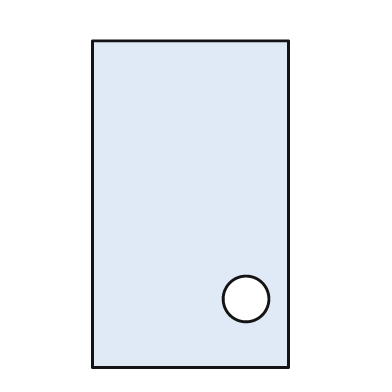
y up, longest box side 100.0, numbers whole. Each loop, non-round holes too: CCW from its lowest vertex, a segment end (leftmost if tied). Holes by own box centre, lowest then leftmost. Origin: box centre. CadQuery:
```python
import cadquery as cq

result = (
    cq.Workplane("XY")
    .moveTo(-30.0, -50.0)
    .lineTo(30.0, -50.0)
    .lineTo(30.0, 50.0)
    .lineTo(-30.0, 50.0)
    .close()
    .moveTo(17.0, -29.0)
    .circle(7.0)
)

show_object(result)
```